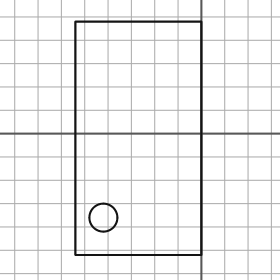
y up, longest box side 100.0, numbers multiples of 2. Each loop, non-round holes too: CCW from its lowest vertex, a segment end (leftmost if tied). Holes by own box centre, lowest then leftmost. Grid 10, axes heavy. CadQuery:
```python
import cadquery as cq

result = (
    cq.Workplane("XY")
    .moveTo(-54.0, -52.0)
    .lineTo(0.0, -52.0)
    .lineTo(0.0, 48.0)
    .lineTo(-54.0, 48.0)
    .close()
    .moveTo(-42.0, -36.0)
    .circle(6.0)
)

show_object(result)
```